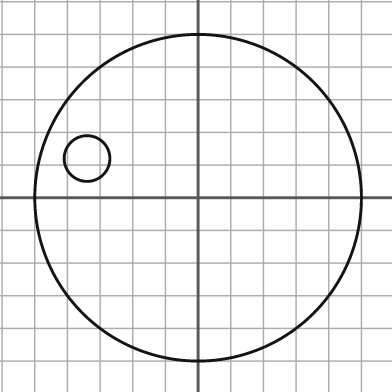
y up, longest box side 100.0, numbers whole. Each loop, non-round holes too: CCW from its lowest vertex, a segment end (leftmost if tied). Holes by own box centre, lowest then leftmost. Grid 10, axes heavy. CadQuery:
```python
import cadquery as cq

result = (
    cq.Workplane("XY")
    .moveTo(0.0, 0.0)
    .circle(50.0)
    .moveTo(-34.0, 12.0)
    .circle(7.0)
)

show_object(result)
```